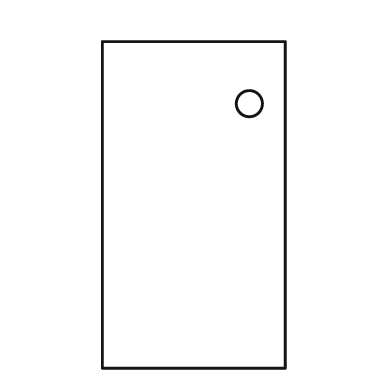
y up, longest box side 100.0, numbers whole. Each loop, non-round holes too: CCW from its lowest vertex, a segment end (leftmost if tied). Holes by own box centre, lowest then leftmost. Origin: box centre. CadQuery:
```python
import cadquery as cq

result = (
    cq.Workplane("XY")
    .moveTo(-28.0, -50.0)
    .lineTo(28.0, -50.0)
    .lineTo(28.0, 50.0)
    .lineTo(-28.0, 50.0)
    .close()
    .moveTo(17.0, 31.0)
    .circle(4.0)
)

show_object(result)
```